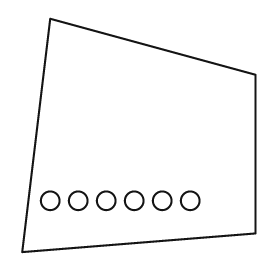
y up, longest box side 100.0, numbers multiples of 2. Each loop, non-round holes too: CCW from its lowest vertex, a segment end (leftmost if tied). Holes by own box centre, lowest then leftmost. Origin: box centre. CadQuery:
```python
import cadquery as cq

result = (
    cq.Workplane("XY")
    .moveTo(-50.0, -50.0)
    .lineTo(50.0, -42.0)
    .lineTo(50.0, 26.0)
    .lineTo(-38.0, 50.0)
    .close()
    .moveTo(-38.0, -28.0)
    .circle(4.0)
    .moveTo(-26.0, -28.0)
    .circle(4.0)
    .moveTo(-14.0, -28.0)
    .circle(4.0)
    .moveTo(-2.0, -28.0)
    .circle(4.0)
    .moveTo(10.0, -28.0)
    .circle(4.0)
    .moveTo(22.0, -28.0)
    .circle(4.0)
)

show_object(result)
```